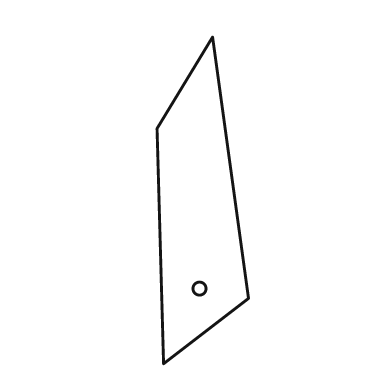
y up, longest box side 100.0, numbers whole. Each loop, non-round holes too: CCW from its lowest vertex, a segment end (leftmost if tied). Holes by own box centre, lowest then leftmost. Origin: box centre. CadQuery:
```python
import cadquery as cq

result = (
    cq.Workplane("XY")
    .moveTo(-12.0, -50.0)
    .lineTo(14.0, -30.0)
    .lineTo(3.0, 50.0)
    .lineTo(-14.0, 22.0)
    .close()
    .moveTo(-1.0, -27.0)
    .circle(2.0)
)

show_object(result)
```